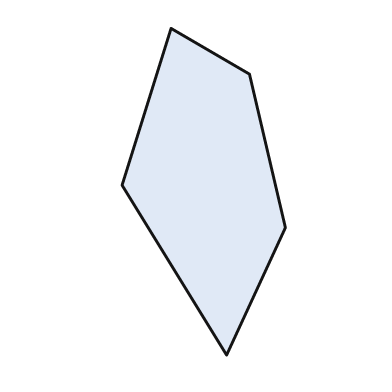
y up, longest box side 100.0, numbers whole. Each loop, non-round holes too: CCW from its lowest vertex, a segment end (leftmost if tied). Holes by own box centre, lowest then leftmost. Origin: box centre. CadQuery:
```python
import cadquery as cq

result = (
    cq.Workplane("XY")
    .moveTo(7.0, -50.0)
    .lineTo(25.0, -11.0)
    .lineTo(14.0, 36.0)
    .lineTo(-10.0, 50.0)
    .lineTo(-25.0, 2.0)
    .close()
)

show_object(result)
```